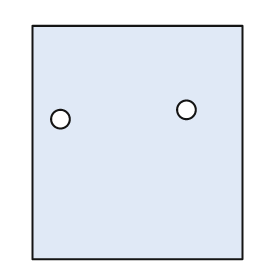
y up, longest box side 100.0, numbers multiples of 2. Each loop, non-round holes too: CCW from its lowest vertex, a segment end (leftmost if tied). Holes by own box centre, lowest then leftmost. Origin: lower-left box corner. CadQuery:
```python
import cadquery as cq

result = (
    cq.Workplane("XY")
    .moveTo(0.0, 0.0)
    .lineTo(90.0, 0.0)
    .lineTo(90.0, 100.0)
    .lineTo(0.0, 100.0)
    .close()
    .moveTo(12.0, 60.0)
    .circle(4.0)
    .moveTo(66.0, 64.0)
    .circle(4.0)
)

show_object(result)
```